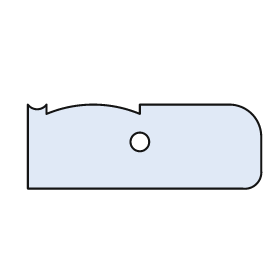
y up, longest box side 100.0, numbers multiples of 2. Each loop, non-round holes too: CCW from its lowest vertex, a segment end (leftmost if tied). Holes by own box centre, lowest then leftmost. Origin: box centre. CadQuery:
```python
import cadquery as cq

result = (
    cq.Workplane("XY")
    .moveTo(-50.0, -18.0)
    .lineTo(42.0, -18.0)
    .threePointArc((48.0, -16.0), (50.0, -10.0))
    .lineTo(50.0, 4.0)
    .threePointArc((46.0, 14.0), (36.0, 18.0))
    .lineTo(-2.0, 18.0)
    .lineTo(-2.0, 14.0)
    .threePointArc((-22.0, 18.0), (-42.0, 14.0))
    .lineTo(-42.0, 18.0)
    .threePointArc((-46.0, 16.0), (-50.0, 18.0))
    .close()
    .moveTo(-2.0, 2.0)
    .circle(4.0)
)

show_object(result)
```